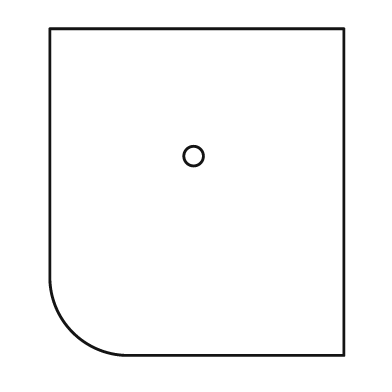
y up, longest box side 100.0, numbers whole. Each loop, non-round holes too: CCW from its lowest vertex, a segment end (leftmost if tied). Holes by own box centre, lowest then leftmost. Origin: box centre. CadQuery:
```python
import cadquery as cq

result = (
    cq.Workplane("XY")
    .moveTo(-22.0, -50.0)
    .lineTo(45.0, -50.0)
    .lineTo(45.0, 50.0)
    .lineTo(-45.0, 50.0)
    .lineTo(-45.0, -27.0)
    .threePointArc((-38.0, -43.0), (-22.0, -50.0))
    .close()
    .moveTo(-1.0, 11.0)
    .circle(3.0)
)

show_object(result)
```